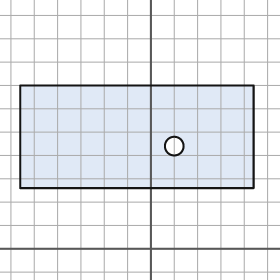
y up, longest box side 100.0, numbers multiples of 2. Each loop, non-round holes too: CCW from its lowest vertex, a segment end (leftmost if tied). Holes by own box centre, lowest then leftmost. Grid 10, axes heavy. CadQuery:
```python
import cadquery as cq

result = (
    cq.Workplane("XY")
    .moveTo(-56.0, 26.0)
    .lineTo(44.0, 26.0)
    .lineTo(44.0, 70.0)
    .lineTo(-56.0, 70.0)
    .close()
    .moveTo(10.0, 44.0)
    .circle(4.0)
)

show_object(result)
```